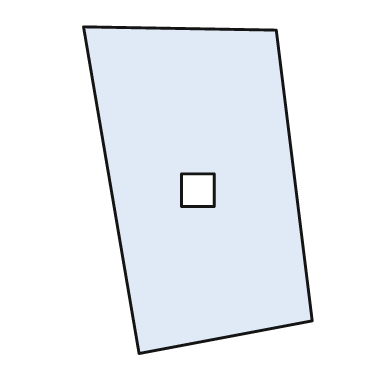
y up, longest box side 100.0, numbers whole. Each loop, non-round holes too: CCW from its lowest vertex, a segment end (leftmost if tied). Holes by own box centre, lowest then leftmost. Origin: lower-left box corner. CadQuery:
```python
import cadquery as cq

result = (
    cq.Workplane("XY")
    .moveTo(17.0, 0.0)
    .lineTo(70.0, 10.0)
    .lineTo(59.0, 99.0)
    .lineTo(0.0, 100.0)
    .close()
    .moveTo(30.0, 45.0)
    .lineTo(40.0, 45.0)
    .lineTo(40.0, 55.0)
    .lineTo(30.0, 55.0)
    .close()
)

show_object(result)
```